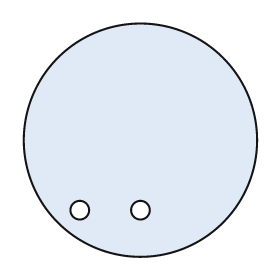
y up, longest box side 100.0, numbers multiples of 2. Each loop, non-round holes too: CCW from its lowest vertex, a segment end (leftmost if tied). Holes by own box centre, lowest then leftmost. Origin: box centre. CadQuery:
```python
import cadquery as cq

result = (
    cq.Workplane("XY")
    .moveTo(0.0, 0.0)
    .circle(50.0)
    .moveTo(-26.0, -30.0)
    .circle(4.0)
    .moveTo(0.0, -30.0)
    .circle(4.0)
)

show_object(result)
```